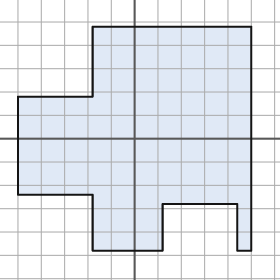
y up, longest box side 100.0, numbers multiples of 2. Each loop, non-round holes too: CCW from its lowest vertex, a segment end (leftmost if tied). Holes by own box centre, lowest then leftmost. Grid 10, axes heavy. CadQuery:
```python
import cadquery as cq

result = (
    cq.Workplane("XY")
    .moveTo(-18.0, -48.0)
    .lineTo(12.0, -48.0)
    .lineTo(12.0, -28.0)
    .lineTo(44.0, -28.0)
    .lineTo(44.0, -48.0)
    .lineTo(50.0, -48.0)
    .lineTo(50.0, 48.0)
    .lineTo(-18.0, 48.0)
    .lineTo(-18.0, 18.0)
    .lineTo(-50.0, 18.0)
    .lineTo(-50.0, -24.0)
    .lineTo(-18.0, -24.0)
    .close()
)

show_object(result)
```